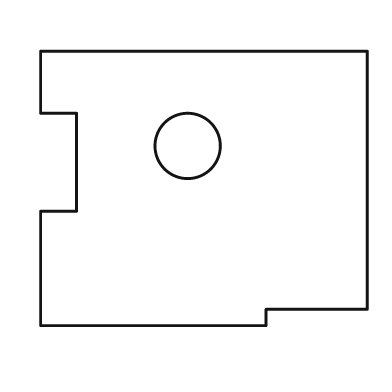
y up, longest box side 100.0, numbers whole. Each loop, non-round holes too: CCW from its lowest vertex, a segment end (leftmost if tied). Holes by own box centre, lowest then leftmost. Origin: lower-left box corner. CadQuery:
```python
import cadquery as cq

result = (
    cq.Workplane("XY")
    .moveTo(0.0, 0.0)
    .lineTo(69.0, 0.0)
    .lineTo(69.0, 5.0)
    .lineTo(100.0, 5.0)
    .lineTo(100.0, 84.0)
    .lineTo(0.0, 84.0)
    .lineTo(0.0, 65.0)
    .lineTo(11.0, 65.0)
    .lineTo(11.0, 35.0)
    .lineTo(0.0, 35.0)
    .close()
    .moveTo(45.0, 55.0)
    .circle(10.0)
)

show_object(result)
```